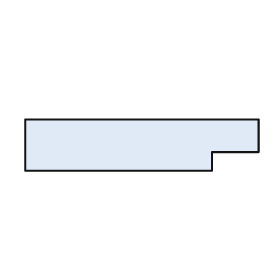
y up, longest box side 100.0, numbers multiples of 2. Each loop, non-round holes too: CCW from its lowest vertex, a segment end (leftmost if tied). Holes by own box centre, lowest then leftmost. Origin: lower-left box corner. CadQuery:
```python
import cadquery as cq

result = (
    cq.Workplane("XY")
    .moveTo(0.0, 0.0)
    .lineTo(80.0, 0.0)
    .lineTo(80.0, 8.0)
    .lineTo(100.0, 8.0)
    .lineTo(100.0, 22.0)
    .lineTo(0.0, 22.0)
    .close()
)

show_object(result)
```